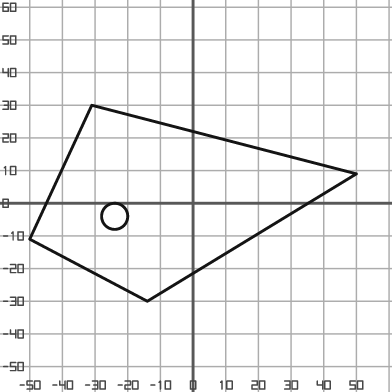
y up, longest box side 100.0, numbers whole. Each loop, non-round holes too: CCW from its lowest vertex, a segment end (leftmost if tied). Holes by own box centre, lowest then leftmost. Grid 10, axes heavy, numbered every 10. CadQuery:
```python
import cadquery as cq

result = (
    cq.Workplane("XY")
    .moveTo(-14.0, -30.0)
    .lineTo(50.0, 9.0)
    .lineTo(-31.0, 30.0)
    .lineTo(-50.0, -11.0)
    .close()
    .moveTo(-24.0, -4.0)
    .circle(4.0)
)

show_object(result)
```